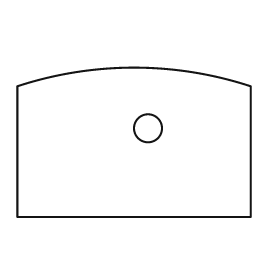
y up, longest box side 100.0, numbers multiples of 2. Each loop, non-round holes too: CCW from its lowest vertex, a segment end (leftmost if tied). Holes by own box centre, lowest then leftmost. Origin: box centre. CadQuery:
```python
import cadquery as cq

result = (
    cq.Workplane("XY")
    .moveTo(-50.0, -32.0)
    .lineTo(50.0, -32.0)
    .lineTo(50.0, 24.0)
    .threePointArc((0.0, 32.0), (-50.0, 24.0))
    .close()
    .moveTo(6.0, 6.0)
    .circle(6.0)
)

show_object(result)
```